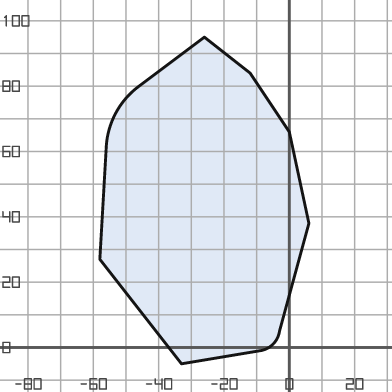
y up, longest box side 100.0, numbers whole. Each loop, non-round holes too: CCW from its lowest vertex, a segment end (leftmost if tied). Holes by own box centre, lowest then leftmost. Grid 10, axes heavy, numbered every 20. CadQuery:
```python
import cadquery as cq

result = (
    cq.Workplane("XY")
    .moveTo(-33.0, -5.0)
    .lineTo(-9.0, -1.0)
    .threePointArc((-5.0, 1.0), (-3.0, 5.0))
    .lineTo(6.0, 38.0)
    .lineTo(0.0, 66.0)
    .lineTo(-12.0, 84.0)
    .lineTo(-26.0, 95.0)
    .lineTo(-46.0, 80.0)
    .threePointArc((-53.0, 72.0), (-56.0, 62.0))
    .lineTo(-58.0, 27.0)
    .close()
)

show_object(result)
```